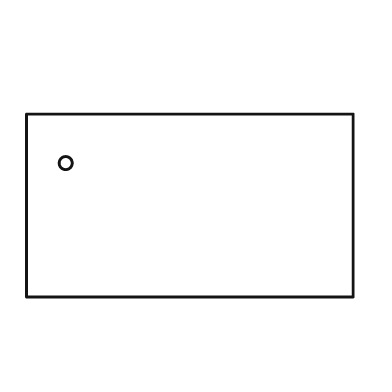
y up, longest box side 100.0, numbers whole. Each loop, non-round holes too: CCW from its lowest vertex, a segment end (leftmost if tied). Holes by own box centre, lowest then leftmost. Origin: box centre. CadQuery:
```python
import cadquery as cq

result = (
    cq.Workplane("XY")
    .moveTo(-50.0, -28.0)
    .lineTo(50.0, -28.0)
    .lineTo(50.0, 28.0)
    .lineTo(-50.0, 28.0)
    .close()
    .moveTo(-38.0, 13.0)
    .circle(2.0)
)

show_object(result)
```